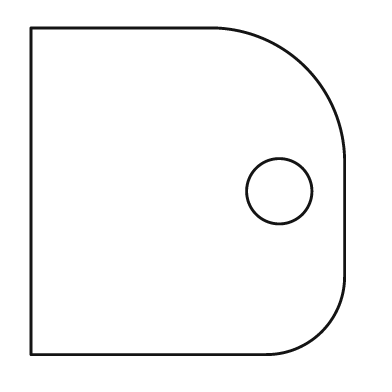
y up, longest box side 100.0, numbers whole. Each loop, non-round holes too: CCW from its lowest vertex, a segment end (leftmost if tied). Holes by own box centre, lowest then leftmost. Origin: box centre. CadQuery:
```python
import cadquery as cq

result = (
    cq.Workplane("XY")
    .moveTo(-48.0, -50.0)
    .lineTo(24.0, -50.0)
    .threePointArc((41.0, -43.0), (48.0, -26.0))
    .lineTo(48.0, 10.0)
    .threePointArc((36.0, 38.0), (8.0, 50.0))
    .lineTo(-48.0, 50.0)
    .close()
    .moveTo(28.0, 0.0)
    .circle(10.0)
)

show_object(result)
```